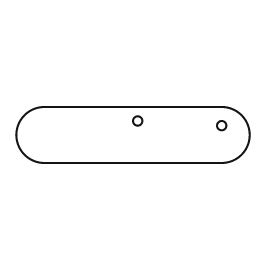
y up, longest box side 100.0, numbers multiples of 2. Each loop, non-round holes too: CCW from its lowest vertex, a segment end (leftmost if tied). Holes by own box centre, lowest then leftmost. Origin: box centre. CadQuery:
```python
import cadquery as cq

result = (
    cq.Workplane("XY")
    .moveTo(-38.0, -12.0)
    .lineTo(38.0, -12.0)
    .threePointArc((50.0, 0.0), (38.0, 12.0))
    .lineTo(-38.0, 12.0)
    .threePointArc((-50.0, 0.0), (-38.0, -12.0))
    .close()
    .moveTo(38.0, 4.0)
    .circle(2.0)
    .moveTo(2.0, 6.0)
    .circle(2.0)
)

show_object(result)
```